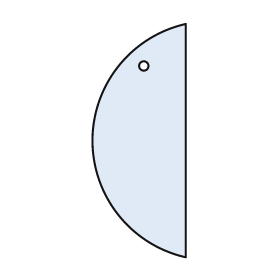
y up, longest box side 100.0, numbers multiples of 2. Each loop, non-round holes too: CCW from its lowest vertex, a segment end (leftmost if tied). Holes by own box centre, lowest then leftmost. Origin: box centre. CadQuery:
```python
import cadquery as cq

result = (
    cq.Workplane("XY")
    .moveTo(20.0, -50.0)
    .lineTo(20.0, 50.0)
    .threePointArc((-20.0, 0.0), (20.0, -50.0))
    .close()
    .moveTo(2.0, 32.0)
    .circle(2.0)
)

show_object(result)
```